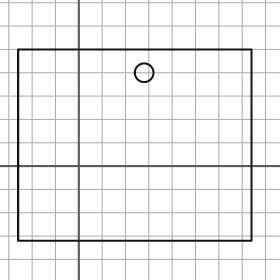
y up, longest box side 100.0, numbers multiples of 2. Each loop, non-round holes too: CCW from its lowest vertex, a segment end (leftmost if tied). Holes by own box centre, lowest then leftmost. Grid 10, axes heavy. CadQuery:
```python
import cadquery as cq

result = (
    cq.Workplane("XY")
    .moveTo(-26.0, -32.0)
    .lineTo(74.0, -32.0)
    .lineTo(74.0, 50.0)
    .lineTo(-26.0, 50.0)
    .close()
    .moveTo(28.0, 40.0)
    .circle(4.0)
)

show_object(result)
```